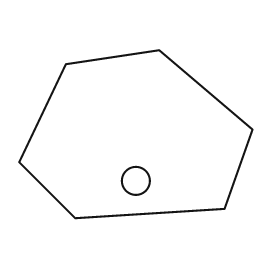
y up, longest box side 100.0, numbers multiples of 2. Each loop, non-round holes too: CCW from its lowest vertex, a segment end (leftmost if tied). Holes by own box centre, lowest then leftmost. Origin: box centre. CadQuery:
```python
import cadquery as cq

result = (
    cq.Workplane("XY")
    .moveTo(-26.0, -36.0)
    .lineTo(38.0, -32.0)
    .lineTo(50.0, 2.0)
    .lineTo(10.0, 36.0)
    .lineTo(-30.0, 30.0)
    .lineTo(-50.0, -12.0)
    .close()
    .moveTo(0.0, -20.0)
    .circle(6.0)
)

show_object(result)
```